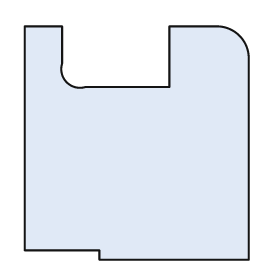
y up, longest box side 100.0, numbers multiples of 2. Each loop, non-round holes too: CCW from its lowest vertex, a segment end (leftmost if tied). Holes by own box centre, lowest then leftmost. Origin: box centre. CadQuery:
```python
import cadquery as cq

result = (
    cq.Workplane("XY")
    .moveTo(-16.0, -50.0)
    .lineTo(48.0, -50.0)
    .lineTo(48.0, 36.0)
    .threePointArc((44.0, 46.0), (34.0, 50.0))
    .lineTo(14.0, 50.0)
    .lineTo(14.0, 24.0)
    .lineTo(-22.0, 24.0)
    .threePointArc((-30.0, 26.0), (-32.0, 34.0))
    .lineTo(-32.0, 50.0)
    .lineTo(-48.0, 50.0)
    .lineTo(-48.0, -46.0)
    .lineTo(-16.0, -46.0)
    .close()
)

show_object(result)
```